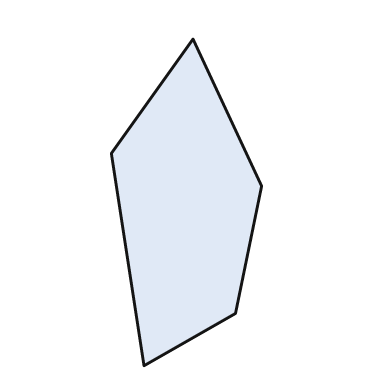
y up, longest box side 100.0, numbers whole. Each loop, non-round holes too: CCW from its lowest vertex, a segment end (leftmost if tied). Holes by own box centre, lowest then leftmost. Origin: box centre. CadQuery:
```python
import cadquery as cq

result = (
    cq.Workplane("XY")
    .moveTo(-13.0, -50.0)
    .lineTo(15.0, -34.0)
    .lineTo(23.0, 5.0)
    .lineTo(2.0, 50.0)
    .lineTo(-23.0, 15.0)
    .close()
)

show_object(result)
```